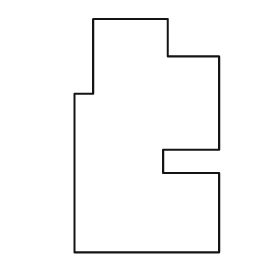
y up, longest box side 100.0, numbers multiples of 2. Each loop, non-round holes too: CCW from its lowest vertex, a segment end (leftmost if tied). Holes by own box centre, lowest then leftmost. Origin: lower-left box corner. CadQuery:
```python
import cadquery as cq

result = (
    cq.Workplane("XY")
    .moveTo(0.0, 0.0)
    .lineTo(62.0, 0.0)
    .lineTo(62.0, 34.0)
    .lineTo(38.0, 34.0)
    .lineTo(38.0, 44.0)
    .lineTo(62.0, 44.0)
    .lineTo(62.0, 84.0)
    .lineTo(40.0, 84.0)
    .lineTo(40.0, 100.0)
    .lineTo(8.0, 100.0)
    .lineTo(8.0, 68.0)
    .lineTo(0.0, 68.0)
    .close()
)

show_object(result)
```